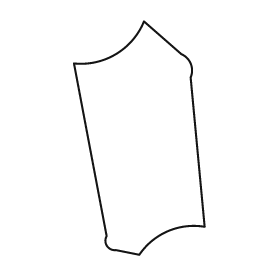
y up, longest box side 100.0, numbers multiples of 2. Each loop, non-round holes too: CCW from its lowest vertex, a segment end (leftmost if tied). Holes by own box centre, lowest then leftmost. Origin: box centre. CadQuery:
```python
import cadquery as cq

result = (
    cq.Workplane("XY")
    .moveTo(0.0, -50.0)
    .threePointArc((12.0, -40.0), (28.0, -38.0))
    .lineTo(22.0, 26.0)
    .threePointArc((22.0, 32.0), (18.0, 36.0))
    .lineTo(2.0, 50.0)
    .threePointArc((-10.0, 36.0), (-28.0, 32.0))
    .lineTo(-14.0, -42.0)
    .threePointArc((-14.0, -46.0), (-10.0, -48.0))
    .close()
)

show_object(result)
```